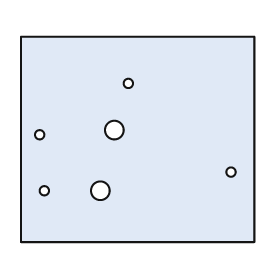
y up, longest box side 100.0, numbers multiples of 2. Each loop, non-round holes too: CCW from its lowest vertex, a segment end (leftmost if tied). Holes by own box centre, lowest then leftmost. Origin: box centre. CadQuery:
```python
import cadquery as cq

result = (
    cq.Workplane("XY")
    .moveTo(-50.0, -44.0)
    .lineTo(50.0, -44.0)
    .lineTo(50.0, 44.0)
    .lineTo(-50.0, 44.0)
    .close()
    .moveTo(-40.0, -22.0)
    .circle(2.0)
    .moveTo(-16.0, -22.0)
    .circle(4.0)
    .moveTo(40.0, -14.0)
    .circle(2.0)
    .moveTo(-42.0, 2.0)
    .circle(2.0)
    .moveTo(-10.0, 4.0)
    .circle(4.0)
    .moveTo(-4.0, 24.0)
    .circle(2.0)
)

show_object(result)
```